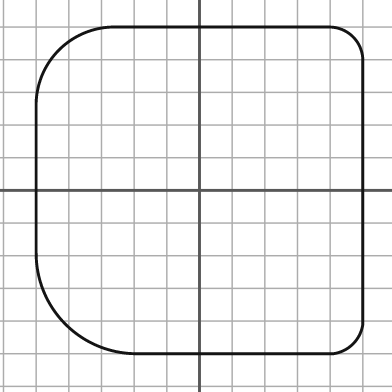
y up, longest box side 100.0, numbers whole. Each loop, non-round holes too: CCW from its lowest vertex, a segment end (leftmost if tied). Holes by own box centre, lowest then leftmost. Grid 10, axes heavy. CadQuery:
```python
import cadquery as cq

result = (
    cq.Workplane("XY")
    .moveTo(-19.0, -50.0)
    .lineTo(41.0, -50.0)
    .threePointArc((47.0, -47.0), (50.0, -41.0))
    .lineTo(50.0, 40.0)
    .threePointArc((47.0, 47.0), (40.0, 50.0))
    .lineTo(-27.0, 50.0)
    .threePointArc((-43.0, 43.0), (-50.0, 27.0))
    .lineTo(-50.0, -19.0)
    .threePointArc((-41.0, -41.0), (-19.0, -50.0))
    .close()
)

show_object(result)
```